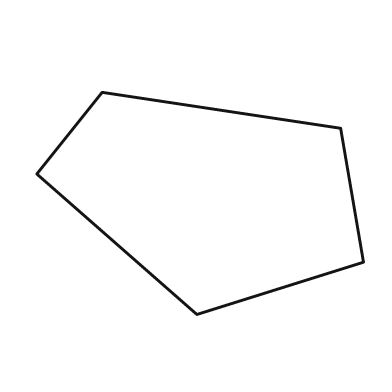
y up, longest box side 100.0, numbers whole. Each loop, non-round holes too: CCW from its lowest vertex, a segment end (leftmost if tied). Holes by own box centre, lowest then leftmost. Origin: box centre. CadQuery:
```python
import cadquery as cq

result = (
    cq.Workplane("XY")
    .moveTo(-1.0, -34.0)
    .lineTo(50.0, -18.0)
    .lineTo(43.0, 23.0)
    .lineTo(-30.0, 34.0)
    .lineTo(-50.0, 9.0)
    .close()
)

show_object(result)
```